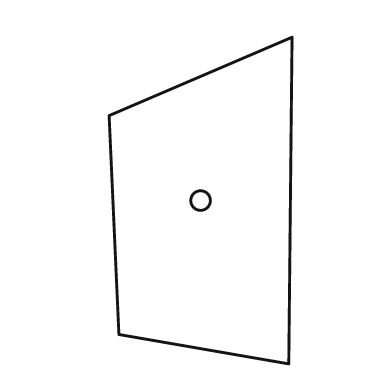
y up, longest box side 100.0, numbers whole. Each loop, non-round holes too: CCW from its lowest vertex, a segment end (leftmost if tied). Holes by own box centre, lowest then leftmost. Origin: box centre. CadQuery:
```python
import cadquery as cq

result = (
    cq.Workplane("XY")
    .moveTo(27.0, -50.0)
    .lineTo(28.0, 50.0)
    .lineTo(-28.0, 26.0)
    .lineTo(-25.0, -41.0)
    .close()
    .moveTo(0.0, 0.0)
    .circle(3.0)
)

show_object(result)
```